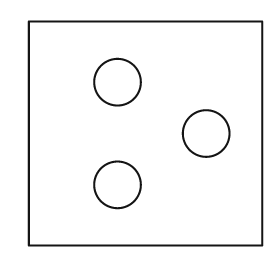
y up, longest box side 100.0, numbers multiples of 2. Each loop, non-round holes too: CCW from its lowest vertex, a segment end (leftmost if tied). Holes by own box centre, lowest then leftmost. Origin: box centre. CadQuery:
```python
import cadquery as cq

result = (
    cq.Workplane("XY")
    .moveTo(-50.0, -48.0)
    .lineTo(50.0, -48.0)
    .lineTo(50.0, 48.0)
    .lineTo(-50.0, 48.0)
    .close()
    .moveTo(-12.0, -22.0)
    .circle(10.0)
    .moveTo(26.0, 0.0)
    .circle(10.0)
    .moveTo(-12.0, 22.0)
    .circle(10.0)
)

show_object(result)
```